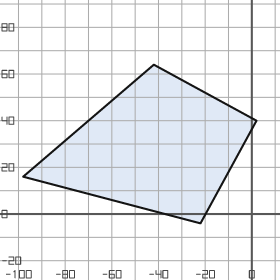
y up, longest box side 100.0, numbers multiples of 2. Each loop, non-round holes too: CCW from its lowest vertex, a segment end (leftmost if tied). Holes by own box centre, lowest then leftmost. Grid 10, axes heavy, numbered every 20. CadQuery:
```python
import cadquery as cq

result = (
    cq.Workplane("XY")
    .moveTo(-22.0, -4.0)
    .lineTo(2.0, 40.0)
    .lineTo(-42.0, 64.0)
    .lineTo(-98.0, 16.0)
    .close()
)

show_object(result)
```